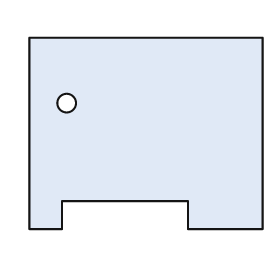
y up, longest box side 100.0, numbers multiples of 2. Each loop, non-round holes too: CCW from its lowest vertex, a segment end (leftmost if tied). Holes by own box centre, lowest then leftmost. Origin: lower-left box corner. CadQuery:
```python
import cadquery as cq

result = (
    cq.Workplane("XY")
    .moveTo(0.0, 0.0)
    .lineTo(14.0, 0.0)
    .lineTo(14.0, 12.0)
    .lineTo(68.0, 12.0)
    .lineTo(68.0, 0.0)
    .lineTo(100.0, 0.0)
    .lineTo(100.0, 82.0)
    .lineTo(0.0, 82.0)
    .close()
    .moveTo(16.0, 54.0)
    .circle(4.0)
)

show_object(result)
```